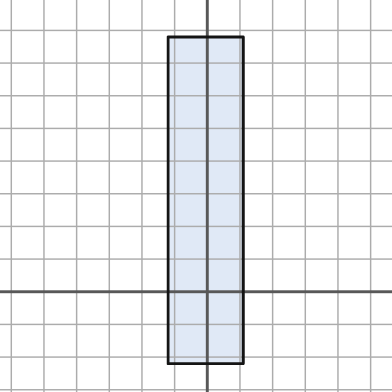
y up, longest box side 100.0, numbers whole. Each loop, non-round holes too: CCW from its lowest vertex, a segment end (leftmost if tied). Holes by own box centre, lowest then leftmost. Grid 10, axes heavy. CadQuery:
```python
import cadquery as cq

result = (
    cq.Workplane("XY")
    .moveTo(-12.0, -22.0)
    .lineTo(11.0, -22.0)
    .lineTo(11.0, 78.0)
    .lineTo(-12.0, 78.0)
    .close()
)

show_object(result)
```